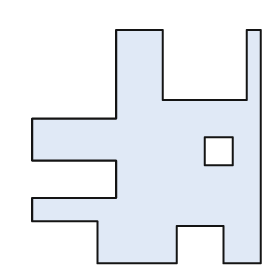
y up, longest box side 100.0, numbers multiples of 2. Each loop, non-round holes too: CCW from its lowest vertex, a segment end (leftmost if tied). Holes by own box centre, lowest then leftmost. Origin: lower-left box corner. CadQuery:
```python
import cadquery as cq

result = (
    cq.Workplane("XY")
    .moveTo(28.0, 0.0)
    .lineTo(62.0, 0.0)
    .lineTo(62.0, 16.0)
    .lineTo(82.0, 16.0)
    .lineTo(82.0, 0.0)
    .lineTo(98.0, 0.0)
    .lineTo(98.0, 100.0)
    .lineTo(92.0, 100.0)
    .lineTo(92.0, 70.0)
    .lineTo(56.0, 70.0)
    .lineTo(56.0, 100.0)
    .lineTo(36.0, 100.0)
    .lineTo(36.0, 62.0)
    .lineTo(0.0, 62.0)
    .lineTo(0.0, 44.0)
    .lineTo(36.0, 44.0)
    .lineTo(36.0, 28.0)
    .lineTo(0.0, 28.0)
    .lineTo(0.0, 18.0)
    .lineTo(28.0, 18.0)
    .close()
    .moveTo(74.0, 42.0)
    .lineTo(86.0, 42.0)
    .lineTo(86.0, 54.0)
    .lineTo(74.0, 54.0)
    .close()
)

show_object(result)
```